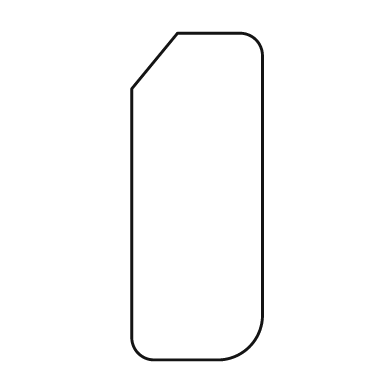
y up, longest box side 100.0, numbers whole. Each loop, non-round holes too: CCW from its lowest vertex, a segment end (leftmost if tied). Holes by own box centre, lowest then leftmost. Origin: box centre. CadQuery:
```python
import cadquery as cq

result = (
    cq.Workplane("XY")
    .moveTo(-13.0, -50.0)
    .lineTo(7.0, -50.0)
    .threePointArc((16.0, -46.0), (20.0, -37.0))
    .lineTo(20.0, 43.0)
    .threePointArc((18.0, 48.0), (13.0, 50.0))
    .lineTo(-6.0, 50.0)
    .lineTo(-20.0, 33.0)
    .lineTo(-20.0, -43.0)
    .threePointArc((-18.0, -48.0), (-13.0, -50.0))
    .close()
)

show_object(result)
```